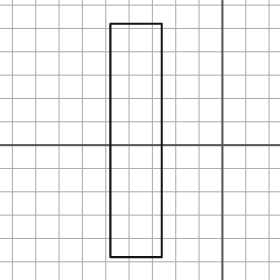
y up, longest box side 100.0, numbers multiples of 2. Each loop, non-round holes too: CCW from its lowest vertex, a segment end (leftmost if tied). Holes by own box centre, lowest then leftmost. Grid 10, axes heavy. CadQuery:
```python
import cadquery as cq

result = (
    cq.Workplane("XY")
    .moveTo(-48.0, -48.0)
    .lineTo(-26.0, -48.0)
    .lineTo(-26.0, 52.0)
    .lineTo(-48.0, 52.0)
    .close()
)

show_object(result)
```